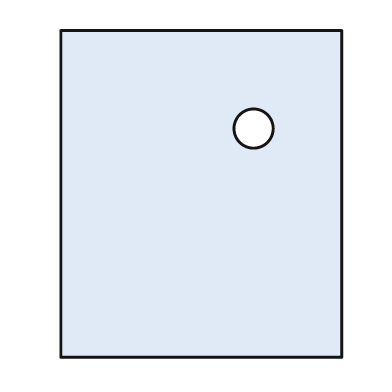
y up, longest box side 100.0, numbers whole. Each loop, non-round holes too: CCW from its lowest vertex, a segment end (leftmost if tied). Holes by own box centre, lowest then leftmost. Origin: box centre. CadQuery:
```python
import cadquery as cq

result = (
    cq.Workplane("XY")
    .moveTo(-43.0, -50.0)
    .lineTo(43.0, -50.0)
    .lineTo(43.0, 50.0)
    .lineTo(-43.0, 50.0)
    .close()
    .moveTo(16.0, 20.0)
    .circle(6.0)
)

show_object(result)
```